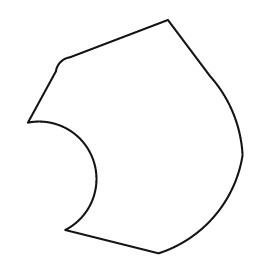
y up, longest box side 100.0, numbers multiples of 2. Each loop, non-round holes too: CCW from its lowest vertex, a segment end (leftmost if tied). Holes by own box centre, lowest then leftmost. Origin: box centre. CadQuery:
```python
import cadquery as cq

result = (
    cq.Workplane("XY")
    .moveTo(10.0, -50.0)
    .threePointArc((34.0, -34.0), (46.0, -8.0))
    .threePointArc((42.0, 10.0), (32.0, 26.0))
    .lineTo(14.0, 50.0)
    .lineTo(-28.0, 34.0)
    .threePointArc((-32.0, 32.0), (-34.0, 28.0))
    .lineTo(-46.0, 6.0)
    .threePointArc((-18.0, -10.0), (-30.0, -40.0))
    .close()
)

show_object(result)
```